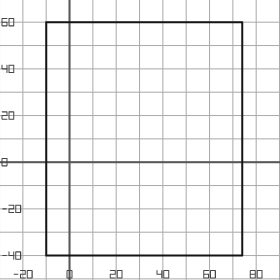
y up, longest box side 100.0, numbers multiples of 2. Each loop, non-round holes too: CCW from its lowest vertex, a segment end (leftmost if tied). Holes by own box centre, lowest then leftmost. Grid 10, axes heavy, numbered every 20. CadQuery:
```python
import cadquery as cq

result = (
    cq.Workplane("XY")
    .moveTo(-10.0, -40.0)
    .lineTo(74.0, -40.0)
    .lineTo(74.0, 60.0)
    .lineTo(-10.0, 60.0)
    .close()
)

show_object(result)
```